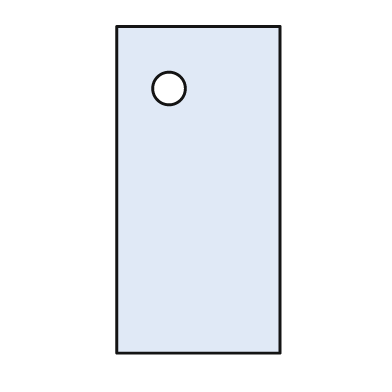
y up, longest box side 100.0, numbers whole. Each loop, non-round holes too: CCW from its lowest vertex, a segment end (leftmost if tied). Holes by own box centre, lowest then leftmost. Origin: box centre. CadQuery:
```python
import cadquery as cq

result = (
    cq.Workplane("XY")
    .moveTo(-25.0, -50.0)
    .lineTo(25.0, -50.0)
    .lineTo(25.0, 50.0)
    .lineTo(-25.0, 50.0)
    .close()
    .moveTo(-9.0, 31.0)
    .circle(5.0)
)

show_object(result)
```